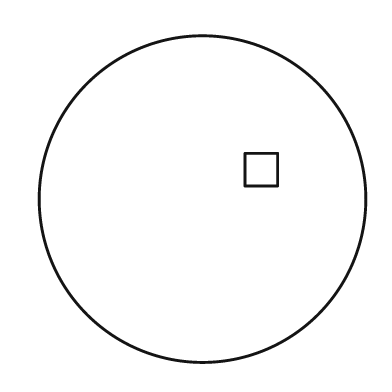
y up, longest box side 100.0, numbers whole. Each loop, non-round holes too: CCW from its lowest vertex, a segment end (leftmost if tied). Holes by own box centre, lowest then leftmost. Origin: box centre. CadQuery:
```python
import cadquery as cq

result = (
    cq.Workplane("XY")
    .moveTo(0.0, 0.0)
    .circle(50.0)
    .moveTo(13.0, 4.0)
    .lineTo(23.0, 4.0)
    .lineTo(23.0, 14.0)
    .lineTo(13.0, 14.0)
    .close()
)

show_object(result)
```